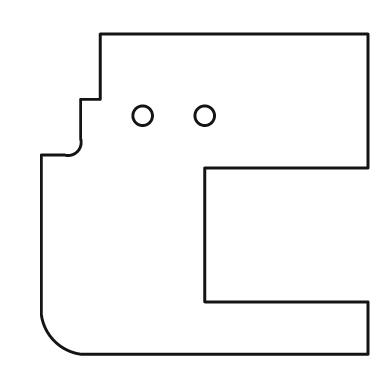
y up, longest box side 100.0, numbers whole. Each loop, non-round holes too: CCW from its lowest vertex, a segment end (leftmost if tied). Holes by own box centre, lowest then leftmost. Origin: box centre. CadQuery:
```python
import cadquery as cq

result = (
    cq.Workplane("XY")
    .moveTo(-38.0, -49.0)
    .lineTo(50.0, -49.0)
    .lineTo(50.0, -33.0)
    .lineTo(0.0, -33.0)
    .lineTo(0.0, 8.0)
    .lineTo(50.0, 8.0)
    .lineTo(50.0, 49.0)
    .lineTo(-32.0, 49.0)
    .lineTo(-32.0, 29.0)
    .lineTo(-38.0, 29.0)
    .lineTo(-38.0, 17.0)
    .threePointArc((-39.0, 13.0), (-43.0, 12.0))
    .lineTo(-50.0, 12.0)
    .lineTo(-50.0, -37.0)
    .threePointArc((-46.0, -45.0), (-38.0, -49.0))
    .close()
    .moveTo(-19.0, 24.0)
    .circle(3.0)
    .moveTo(0.0, 24.0)
    .circle(3.0)
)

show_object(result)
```